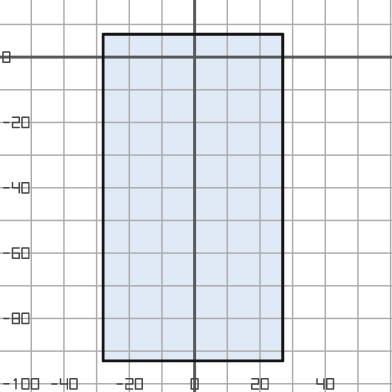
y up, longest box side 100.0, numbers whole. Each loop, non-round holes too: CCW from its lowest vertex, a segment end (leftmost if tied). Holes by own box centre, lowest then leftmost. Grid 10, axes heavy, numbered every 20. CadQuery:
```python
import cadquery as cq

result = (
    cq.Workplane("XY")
    .moveTo(-28.0, -93.0)
    .lineTo(27.0, -93.0)
    .lineTo(27.0, 7.0)
    .lineTo(-28.0, 7.0)
    .close()
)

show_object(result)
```